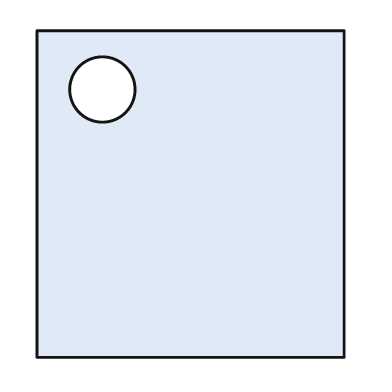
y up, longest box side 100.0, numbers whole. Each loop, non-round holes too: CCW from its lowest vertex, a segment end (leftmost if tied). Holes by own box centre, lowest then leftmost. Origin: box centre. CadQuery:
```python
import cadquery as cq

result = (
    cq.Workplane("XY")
    .moveTo(-47.0, -50.0)
    .lineTo(47.0, -50.0)
    .lineTo(47.0, 50.0)
    .lineTo(-47.0, 50.0)
    .close()
    .moveTo(-27.0, 32.0)
    .circle(10.0)
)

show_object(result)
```